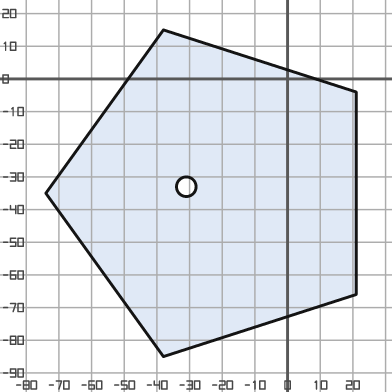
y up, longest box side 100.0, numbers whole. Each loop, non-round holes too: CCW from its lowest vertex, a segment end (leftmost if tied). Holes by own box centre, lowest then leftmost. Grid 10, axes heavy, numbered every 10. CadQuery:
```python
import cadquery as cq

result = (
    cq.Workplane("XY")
    .moveTo(-38.0, -85.0)
    .lineTo(21.0, -66.0)
    .lineTo(21.0, -4.0)
    .lineTo(-38.0, 15.0)
    .lineTo(-74.0, -35.0)
    .close()
    .moveTo(-31.0, -33.0)
    .circle(3.0)
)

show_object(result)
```